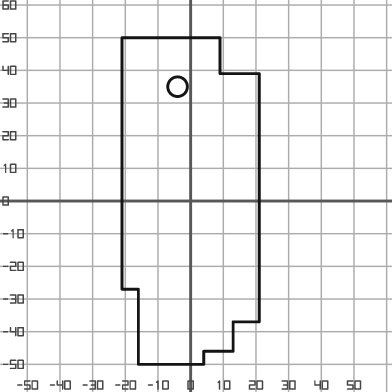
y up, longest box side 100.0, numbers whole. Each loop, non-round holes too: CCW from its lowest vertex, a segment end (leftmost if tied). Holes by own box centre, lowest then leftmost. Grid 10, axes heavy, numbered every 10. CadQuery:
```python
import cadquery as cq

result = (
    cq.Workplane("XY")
    .moveTo(-16.0, -50.0)
    .lineTo(4.0, -50.0)
    .lineTo(4.0, -46.0)
    .lineTo(13.0, -46.0)
    .lineTo(13.0, -37.0)
    .lineTo(21.0, -37.0)
    .lineTo(21.0, 39.0)
    .lineTo(9.0, 39.0)
    .lineTo(9.0, 50.0)
    .lineTo(-21.0, 50.0)
    .lineTo(-21.0, -27.0)
    .lineTo(-16.0, -27.0)
    .close()
    .moveTo(-4.0, 35.0)
    .circle(3.0)
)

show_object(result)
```